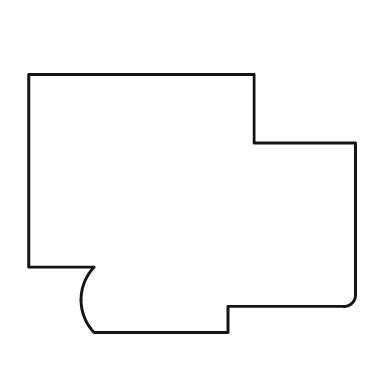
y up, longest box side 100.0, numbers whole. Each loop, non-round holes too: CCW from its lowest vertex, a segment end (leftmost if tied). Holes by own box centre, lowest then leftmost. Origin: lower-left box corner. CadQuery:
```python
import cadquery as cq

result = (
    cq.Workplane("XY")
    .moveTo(20.0, 0.0)
    .lineTo(61.0, 0.0)
    .lineTo(61.0, 8.0)
    .lineTo(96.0, 8.0)
    .threePointArc((99.0, 9.0), (100.0, 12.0))
    .lineTo(100.0, 58.0)
    .lineTo(69.0, 58.0)
    .lineTo(69.0, 79.0)
    .lineTo(0.0, 79.0)
    .lineTo(0.0, 20.0)
    .lineTo(20.0, 20.0)
    .threePointArc((16.0, 10.0), (20.0, 0.0))
    .close()
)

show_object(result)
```